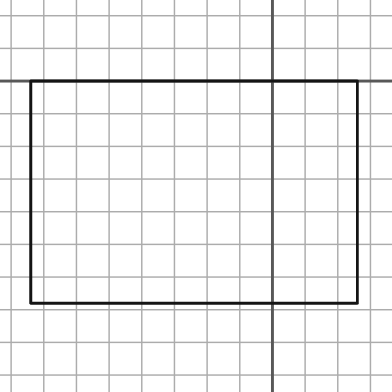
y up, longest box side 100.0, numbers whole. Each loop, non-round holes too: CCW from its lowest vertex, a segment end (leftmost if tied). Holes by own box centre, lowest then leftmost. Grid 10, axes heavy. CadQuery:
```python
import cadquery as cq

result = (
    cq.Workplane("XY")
    .moveTo(-74.0, -68.0)
    .lineTo(26.0, -68.0)
    .lineTo(26.0, 0.0)
    .lineTo(-74.0, 0.0)
    .close()
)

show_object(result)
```